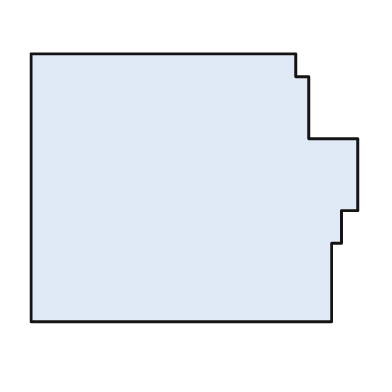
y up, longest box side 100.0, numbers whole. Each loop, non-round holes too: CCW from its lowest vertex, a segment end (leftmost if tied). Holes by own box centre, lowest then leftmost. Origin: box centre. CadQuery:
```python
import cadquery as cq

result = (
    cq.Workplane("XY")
    .moveTo(-50.0, -41.0)
    .lineTo(42.0, -41.0)
    .lineTo(42.0, -17.0)
    .lineTo(45.0, -17.0)
    .lineTo(45.0, -7.0)
    .lineTo(50.0, -7.0)
    .lineTo(50.0, 15.0)
    .lineTo(35.0, 15.0)
    .lineTo(35.0, 34.0)
    .lineTo(31.0, 34.0)
    .lineTo(31.0, 41.0)
    .lineTo(-50.0, 41.0)
    .close()
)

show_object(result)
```